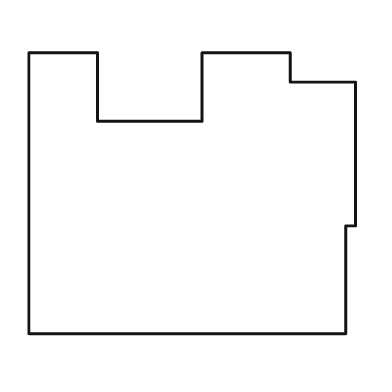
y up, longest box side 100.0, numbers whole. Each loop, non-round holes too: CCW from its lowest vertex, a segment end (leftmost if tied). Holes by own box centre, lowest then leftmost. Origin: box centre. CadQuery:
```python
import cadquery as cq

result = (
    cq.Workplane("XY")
    .moveTo(-50.0, -43.0)
    .lineTo(47.0, -43.0)
    .lineTo(47.0, -10.0)
    .lineTo(50.0, -10.0)
    .lineTo(50.0, 34.0)
    .lineTo(30.0, 34.0)
    .lineTo(30.0, 43.0)
    .lineTo(3.0, 43.0)
    .lineTo(3.0, 22.0)
    .lineTo(-29.0, 22.0)
    .lineTo(-29.0, 43.0)
    .lineTo(-50.0, 43.0)
    .close()
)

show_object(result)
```